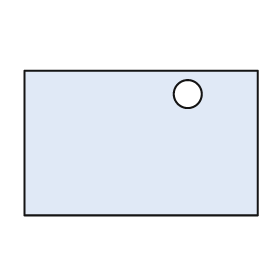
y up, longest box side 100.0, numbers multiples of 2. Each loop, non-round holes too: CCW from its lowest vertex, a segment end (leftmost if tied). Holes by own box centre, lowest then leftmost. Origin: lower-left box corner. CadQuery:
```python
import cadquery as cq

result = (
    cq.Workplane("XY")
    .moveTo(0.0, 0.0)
    .lineTo(100.0, 0.0)
    .lineTo(100.0, 62.0)
    .lineTo(0.0, 62.0)
    .close()
    .moveTo(70.0, 52.0)
    .circle(6.0)
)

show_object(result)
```